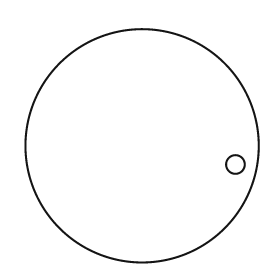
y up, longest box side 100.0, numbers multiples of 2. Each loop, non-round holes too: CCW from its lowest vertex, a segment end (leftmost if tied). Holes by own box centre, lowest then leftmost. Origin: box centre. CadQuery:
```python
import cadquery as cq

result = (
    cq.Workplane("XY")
    .moveTo(0.0, 0.0)
    .circle(50.0)
    .moveTo(40.0, -8.0)
    .circle(4.0)
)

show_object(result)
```